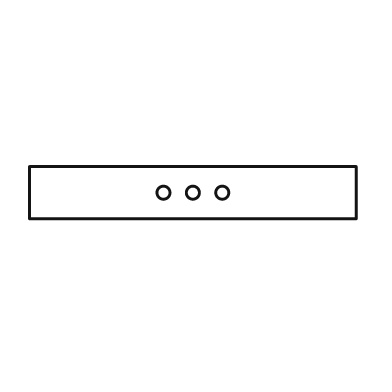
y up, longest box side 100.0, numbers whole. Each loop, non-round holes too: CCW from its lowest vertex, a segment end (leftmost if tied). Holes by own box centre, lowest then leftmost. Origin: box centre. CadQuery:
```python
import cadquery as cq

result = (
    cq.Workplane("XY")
    .moveTo(-50.0, -8.0)
    .lineTo(50.0, -8.0)
    .lineTo(50.0, 8.0)
    .lineTo(-50.0, 8.0)
    .close()
    .moveTo(-9.0, 0.0)
    .circle(2.0)
    .moveTo(0.0, 0.0)
    .circle(2.0)
    .moveTo(9.0, 0.0)
    .circle(2.0)
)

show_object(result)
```